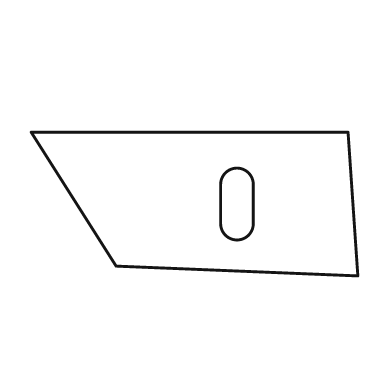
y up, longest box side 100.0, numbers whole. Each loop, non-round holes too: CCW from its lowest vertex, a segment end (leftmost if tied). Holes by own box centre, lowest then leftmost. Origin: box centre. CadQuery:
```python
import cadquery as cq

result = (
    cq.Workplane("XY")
    .moveTo(50.0, -22.0)
    .lineTo(47.0, 22.0)
    .lineTo(-50.0, 22.0)
    .lineTo(-24.0, -19.0)
    .close()
    .moveTo(8.0, -6.0)
    .threePointArc((13.0, -11.0), (18.0, -6.0))
    .lineTo(18.0, 6.0)
    .threePointArc((13.0, 11.0), (8.0, 6.0))
    .close()
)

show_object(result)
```